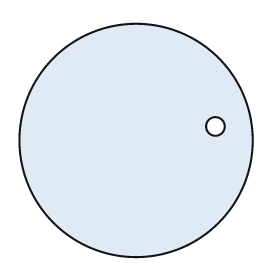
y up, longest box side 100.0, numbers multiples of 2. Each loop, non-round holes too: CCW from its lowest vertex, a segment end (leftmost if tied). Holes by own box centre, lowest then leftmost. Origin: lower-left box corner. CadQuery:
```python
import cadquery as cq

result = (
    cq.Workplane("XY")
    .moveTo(50.0, 50.0)
    .circle(50.0)
    .moveTo(84.0, 56.0)
    .circle(4.0)
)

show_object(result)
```